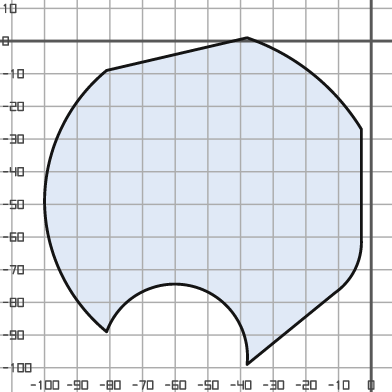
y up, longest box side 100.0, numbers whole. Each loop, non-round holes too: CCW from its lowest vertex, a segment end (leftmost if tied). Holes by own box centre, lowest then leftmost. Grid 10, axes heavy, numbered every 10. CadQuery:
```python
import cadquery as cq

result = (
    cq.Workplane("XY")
    .moveTo(-38.0, -99.0)
    .lineTo(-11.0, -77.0)
    .threePointArc((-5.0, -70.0), (-3.0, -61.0))
    .lineTo(-3.0, -27.0)
    .threePointArc((-18.0, -10.0), (-38.0, 1.0))
    .lineTo(-81.0, -9.0)
    .threePointArc((-95.0, -27.0), (-100.0, -49.0))
    .threePointArc((-95.0, -71.0), (-81.0, -89.0))
    .threePointArc((-55.0, -75.0), (-38.0, -99.0))
    .close()
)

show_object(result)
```